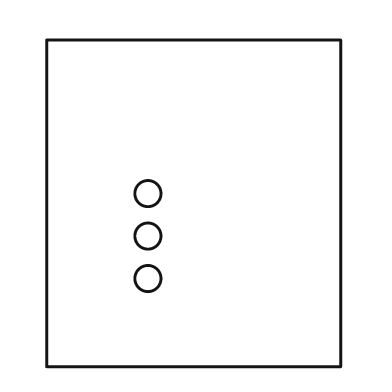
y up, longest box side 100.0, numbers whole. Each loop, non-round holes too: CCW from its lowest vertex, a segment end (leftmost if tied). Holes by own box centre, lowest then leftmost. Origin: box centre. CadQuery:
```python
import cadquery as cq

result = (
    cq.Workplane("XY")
    .moveTo(-45.0, -50.0)
    .lineTo(45.0, -50.0)
    .lineTo(45.0, 50.0)
    .lineTo(-45.0, 50.0)
    .close()
    .moveTo(-14.0, -23.0)
    .circle(4.0)
    .moveTo(-14.0, -10.0)
    .circle(4.0)
    .moveTo(-14.0, 3.0)
    .circle(4.0)
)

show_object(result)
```